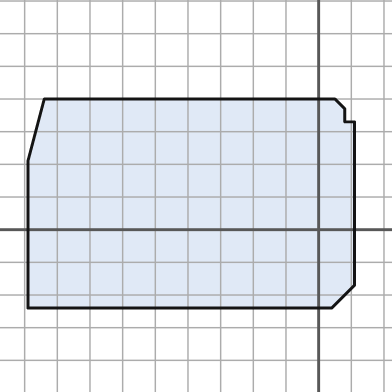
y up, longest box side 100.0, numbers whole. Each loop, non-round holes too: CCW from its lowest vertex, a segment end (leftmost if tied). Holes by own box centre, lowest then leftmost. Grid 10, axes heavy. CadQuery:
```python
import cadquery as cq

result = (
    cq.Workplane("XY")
    .moveTo(-89.0, -24.0)
    .lineTo(4.0, -24.0)
    .lineTo(11.0, -17.0)
    .lineTo(11.0, 33.0)
    .lineTo(8.0, 33.0)
    .lineTo(8.0, 37.0)
    .lineTo(5.0, 40.0)
    .lineTo(-84.0, 40.0)
    .lineTo(-89.0, 21.0)
    .close()
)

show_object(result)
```